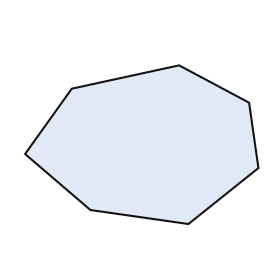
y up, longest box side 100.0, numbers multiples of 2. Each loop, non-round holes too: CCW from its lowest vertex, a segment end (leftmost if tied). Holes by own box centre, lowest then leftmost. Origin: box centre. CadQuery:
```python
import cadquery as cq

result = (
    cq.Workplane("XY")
    .moveTo(20.0, -34.0)
    .lineTo(50.0, -10.0)
    .lineTo(46.0, 18.0)
    .lineTo(16.0, 34.0)
    .lineTo(-30.0, 24.0)
    .lineTo(-50.0, -4.0)
    .lineTo(-22.0, -28.0)
    .close()
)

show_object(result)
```